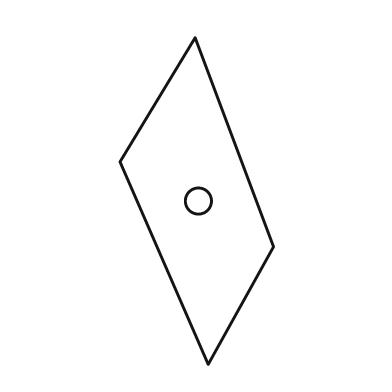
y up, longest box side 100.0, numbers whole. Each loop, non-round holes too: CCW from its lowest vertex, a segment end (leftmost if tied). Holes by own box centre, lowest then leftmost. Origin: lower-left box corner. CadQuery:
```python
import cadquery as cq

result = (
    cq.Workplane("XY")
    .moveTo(27.0, 0.0)
    .lineTo(47.0, 36.0)
    .lineTo(23.0, 100.0)
    .lineTo(0.0, 62.0)
    .close()
    .moveTo(24.0, 50.0)
    .circle(4.0)
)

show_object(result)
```